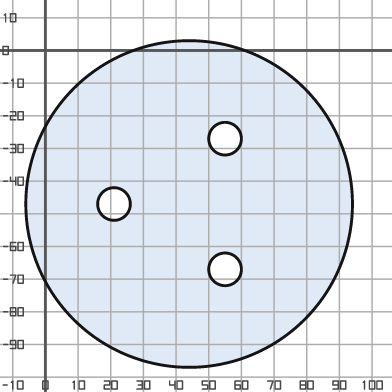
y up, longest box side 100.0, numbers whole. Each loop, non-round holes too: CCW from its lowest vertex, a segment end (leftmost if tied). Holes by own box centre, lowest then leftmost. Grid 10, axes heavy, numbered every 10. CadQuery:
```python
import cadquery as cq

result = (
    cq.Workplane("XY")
    .moveTo(44.0, -47.0)
    .circle(50.0)
    .moveTo(55.0, -67.0)
    .circle(5.0)
    .moveTo(21.0, -47.0)
    .circle(5.0)
    .moveTo(55.0, -27.0)
    .circle(5.0)
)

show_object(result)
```